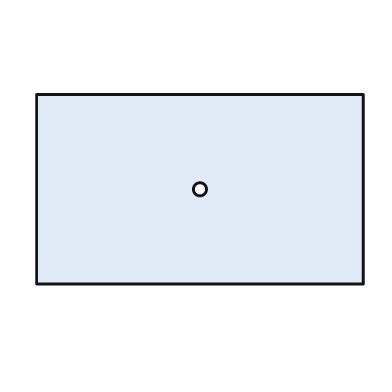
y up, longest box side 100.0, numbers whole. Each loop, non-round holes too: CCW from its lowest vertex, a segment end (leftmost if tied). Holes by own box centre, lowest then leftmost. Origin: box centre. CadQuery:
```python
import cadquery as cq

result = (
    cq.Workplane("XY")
    .moveTo(-50.0, -29.0)
    .lineTo(50.0, -29.0)
    .lineTo(50.0, 29.0)
    .lineTo(-50.0, 29.0)
    .close()
    .moveTo(0.0, 0.0)
    .circle(2.0)
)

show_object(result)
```